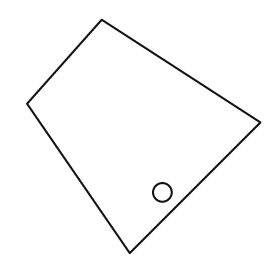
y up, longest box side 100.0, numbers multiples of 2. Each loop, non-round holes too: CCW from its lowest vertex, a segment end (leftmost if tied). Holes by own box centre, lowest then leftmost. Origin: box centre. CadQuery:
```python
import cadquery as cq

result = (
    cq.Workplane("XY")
    .moveTo(-6.0, -50.0)
    .lineTo(50.0, 6.0)
    .lineTo(-18.0, 50.0)
    .lineTo(-50.0, 14.0)
    .close()
    .moveTo(8.0, -24.0)
    .circle(4.0)
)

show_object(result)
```